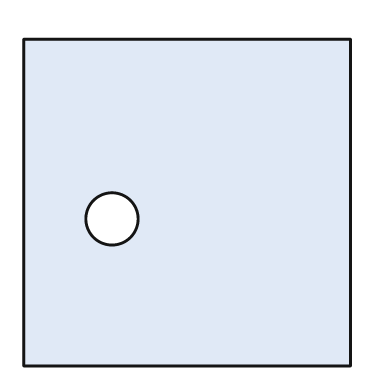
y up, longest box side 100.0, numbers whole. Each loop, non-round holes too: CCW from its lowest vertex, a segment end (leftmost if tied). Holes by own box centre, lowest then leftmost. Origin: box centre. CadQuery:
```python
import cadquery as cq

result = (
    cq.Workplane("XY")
    .moveTo(-50.0, -50.0)
    .lineTo(50.0, -50.0)
    .lineTo(50.0, 50.0)
    .lineTo(-50.0, 50.0)
    .close()
    .moveTo(-23.0, -5.0)
    .circle(8.0)
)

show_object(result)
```